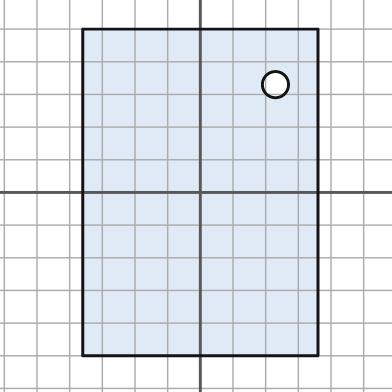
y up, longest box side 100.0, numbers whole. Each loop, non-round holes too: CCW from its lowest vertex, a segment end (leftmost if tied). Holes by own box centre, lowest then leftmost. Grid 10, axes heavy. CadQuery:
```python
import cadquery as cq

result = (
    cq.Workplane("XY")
    .moveTo(-36.0, -50.0)
    .lineTo(36.0, -50.0)
    .lineTo(36.0, 50.0)
    .lineTo(-36.0, 50.0)
    .close()
    .moveTo(23.0, 33.0)
    .circle(4.0)
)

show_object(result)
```